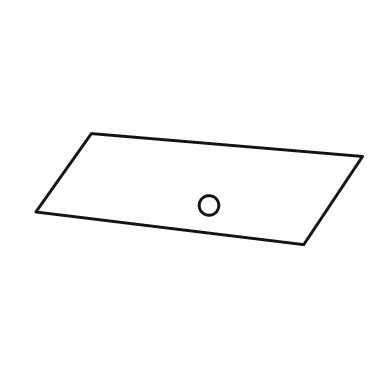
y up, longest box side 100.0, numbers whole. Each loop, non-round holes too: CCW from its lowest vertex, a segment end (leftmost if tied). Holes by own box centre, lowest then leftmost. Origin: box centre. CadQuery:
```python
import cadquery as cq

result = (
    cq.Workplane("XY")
    .moveTo(32.0, -17.0)
    .lineTo(50.0, 10.0)
    .lineTo(-33.0, 17.0)
    .lineTo(-50.0, -7.0)
    .close()
    .moveTo(3.0, -5.0)
    .circle(3.0)
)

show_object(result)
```